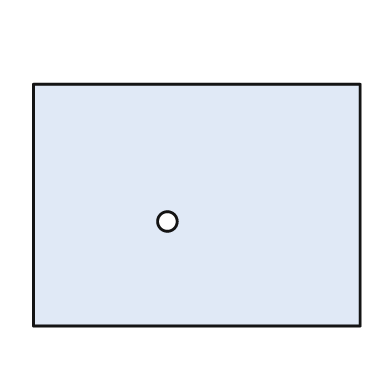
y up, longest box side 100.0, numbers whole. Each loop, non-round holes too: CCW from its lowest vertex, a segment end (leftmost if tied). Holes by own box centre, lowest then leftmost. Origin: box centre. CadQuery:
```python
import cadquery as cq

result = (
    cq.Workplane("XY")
    .moveTo(-50.0, -37.0)
    .lineTo(50.0, -37.0)
    .lineTo(50.0, 37.0)
    .lineTo(-50.0, 37.0)
    .close()
    .moveTo(-9.0, -5.0)
    .circle(3.0)
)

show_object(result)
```